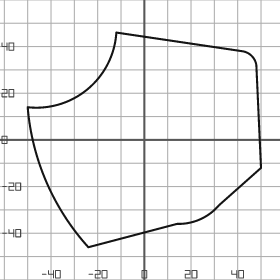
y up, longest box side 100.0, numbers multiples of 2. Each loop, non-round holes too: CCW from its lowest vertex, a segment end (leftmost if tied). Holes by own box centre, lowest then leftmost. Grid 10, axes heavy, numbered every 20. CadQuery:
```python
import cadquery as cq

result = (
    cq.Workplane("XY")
    .moveTo(-24.0, -46.0)
    .lineTo(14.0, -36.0)
    .threePointArc((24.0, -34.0), (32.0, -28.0))
    .lineTo(50.0, -12.0)
    .lineTo(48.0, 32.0)
    .threePointArc((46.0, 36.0), (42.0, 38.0))
    .lineTo(-12.0, 46.0)
    .threePointArc((-24.0, 22.0), (-50.0, 14.0))
    .threePointArc((-42.0, -18.0), (-24.0, -46.0))
    .close()
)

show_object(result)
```